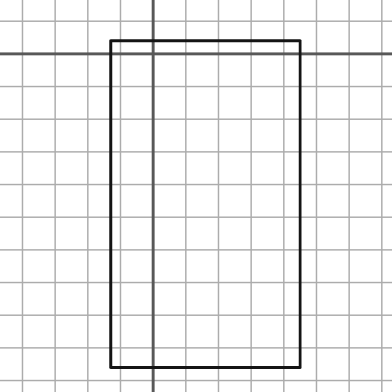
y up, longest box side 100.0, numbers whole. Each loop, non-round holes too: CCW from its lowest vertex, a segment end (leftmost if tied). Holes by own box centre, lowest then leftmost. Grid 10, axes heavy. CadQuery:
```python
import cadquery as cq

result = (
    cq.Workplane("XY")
    .moveTo(-13.0, -96.0)
    .lineTo(45.0, -96.0)
    .lineTo(45.0, 4.0)
    .lineTo(-13.0, 4.0)
    .close()
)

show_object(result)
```